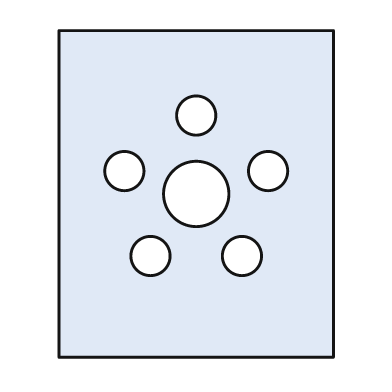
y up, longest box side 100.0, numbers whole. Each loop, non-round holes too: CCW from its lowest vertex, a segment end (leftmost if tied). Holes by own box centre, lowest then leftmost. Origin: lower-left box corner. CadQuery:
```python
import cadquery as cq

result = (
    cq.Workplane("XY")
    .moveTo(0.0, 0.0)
    .lineTo(84.0, 0.0)
    .lineTo(84.0, 100.0)
    .lineTo(0.0, 100.0)
    .close()
    .moveTo(28.0, 31.0)
    .circle(6.0)
    .moveTo(56.0, 31.0)
    .circle(6.0)
    .moveTo(42.0, 50.0)
    .circle(10.0)
    .moveTo(20.0, 57.0)
    .circle(6.0)
    .moveTo(64.0, 57.0)
    .circle(6.0)
    .moveTo(42.0, 74.0)
    .circle(6.0)
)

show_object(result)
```